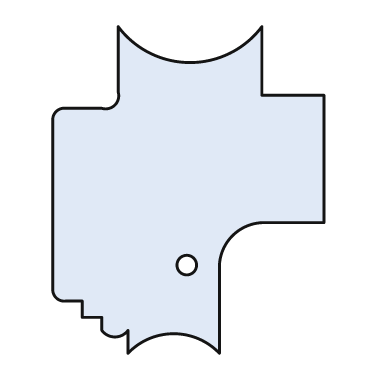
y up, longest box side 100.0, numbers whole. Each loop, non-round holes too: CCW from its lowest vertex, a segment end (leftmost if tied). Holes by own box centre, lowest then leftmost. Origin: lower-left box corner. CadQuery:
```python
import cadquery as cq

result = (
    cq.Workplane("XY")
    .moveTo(23.0, 0.0)
    .threePointArc((37.0, 6.0), (51.0, 0.0))
    .lineTo(51.0, 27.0)
    .threePointArc((55.0, 36.0), (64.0, 40.0))
    .lineTo(83.0, 40.0)
    .lineTo(83.0, 79.0)
    .lineTo(64.0, 79.0)
    .lineTo(64.0, 100.0)
    .threePointArc((42.0, 89.0), (20.0, 100.0))
    .lineTo(20.0, 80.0)
    .threePointArc((19.0, 76.0), (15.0, 75.0))
    .lineTo(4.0, 75.0)
    .threePointArc((1.0, 74.0), (0.0, 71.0))
    .lineTo(0.0, 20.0)
    .threePointArc((1.0, 17.0), (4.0, 16.0))
    .lineTo(9.0, 16.0)
    .lineTo(9.0, 11.0)
    .lineTo(15.0, 11.0)
    .lineTo(15.0, 7.0)
    .threePointArc((19.0, 5.0), (23.0, 7.0))
    .close()
    .moveTo(41.0, 27.0)
    .circle(3.0)
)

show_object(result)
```